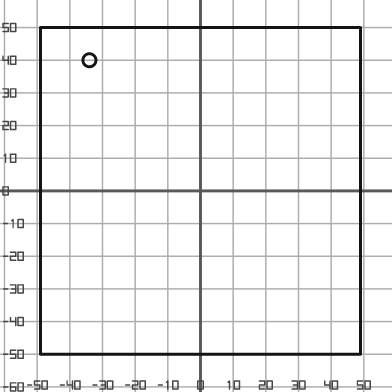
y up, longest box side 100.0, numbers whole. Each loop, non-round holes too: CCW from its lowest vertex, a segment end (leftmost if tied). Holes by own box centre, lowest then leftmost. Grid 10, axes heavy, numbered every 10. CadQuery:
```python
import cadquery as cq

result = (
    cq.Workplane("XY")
    .moveTo(-49.0, -50.0)
    .lineTo(49.0, -50.0)
    .lineTo(49.0, 50.0)
    .lineTo(-49.0, 50.0)
    .close()
    .moveTo(-34.0, 40.0)
    .circle(2.0)
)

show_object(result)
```